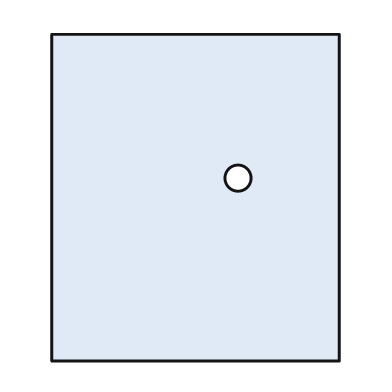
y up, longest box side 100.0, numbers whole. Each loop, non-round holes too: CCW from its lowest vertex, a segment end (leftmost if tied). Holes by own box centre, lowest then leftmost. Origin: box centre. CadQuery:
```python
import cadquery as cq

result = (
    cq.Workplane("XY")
    .moveTo(-44.0, -50.0)
    .lineTo(44.0, -50.0)
    .lineTo(44.0, 50.0)
    .lineTo(-44.0, 50.0)
    .close()
    .moveTo(13.0, 6.0)
    .circle(4.0)
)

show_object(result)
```